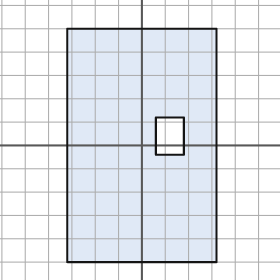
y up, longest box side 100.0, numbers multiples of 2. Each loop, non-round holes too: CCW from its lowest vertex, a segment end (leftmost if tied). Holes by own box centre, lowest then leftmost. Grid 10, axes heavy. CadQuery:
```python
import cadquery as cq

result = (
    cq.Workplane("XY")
    .moveTo(-32.0, -50.0)
    .lineTo(32.0, -50.0)
    .lineTo(32.0, 50.0)
    .lineTo(-32.0, 50.0)
    .close()
    .moveTo(6.0, -4.0)
    .lineTo(18.0, -4.0)
    .lineTo(18.0, 12.0)
    .lineTo(6.0, 12.0)
    .close()
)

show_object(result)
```